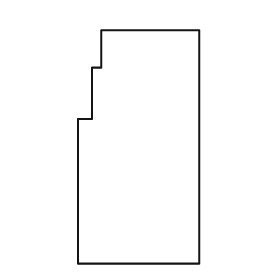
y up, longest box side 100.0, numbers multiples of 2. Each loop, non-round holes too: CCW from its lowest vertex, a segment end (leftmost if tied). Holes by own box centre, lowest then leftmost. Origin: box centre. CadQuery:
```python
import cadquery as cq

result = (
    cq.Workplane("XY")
    .moveTo(-26.0, -50.0)
    .lineTo(26.0, -50.0)
    .lineTo(26.0, 50.0)
    .lineTo(-16.0, 50.0)
    .lineTo(-16.0, 34.0)
    .lineTo(-20.0, 34.0)
    .lineTo(-20.0, 12.0)
    .lineTo(-26.0, 12.0)
    .close()
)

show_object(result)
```